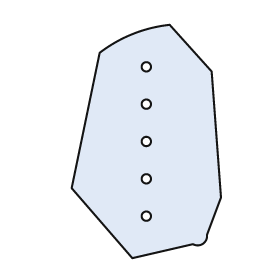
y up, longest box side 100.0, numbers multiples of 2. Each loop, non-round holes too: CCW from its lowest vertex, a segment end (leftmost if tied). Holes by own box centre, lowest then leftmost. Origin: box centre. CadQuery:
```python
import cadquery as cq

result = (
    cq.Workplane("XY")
    .moveTo(-6.0, -50.0)
    .lineTo(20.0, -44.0)
    .threePointArc((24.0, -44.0), (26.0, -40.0))
    .lineTo(32.0, -24.0)
    .lineTo(28.0, 30.0)
    .lineTo(10.0, 50.0)
    .threePointArc((-6.0, 46.0), (-20.0, 38.0))
    .lineTo(-32.0, -20.0)
    .close()
    .moveTo(0.0, -32.0)
    .circle(2.0)
    .moveTo(0.0, -16.0)
    .circle(2.0)
    .moveTo(0.0, 0.0)
    .circle(2.0)
    .moveTo(0.0, 16.0)
    .circle(2.0)
    .moveTo(0.0, 32.0)
    .circle(2.0)
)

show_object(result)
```